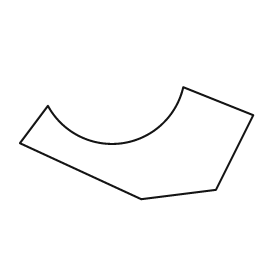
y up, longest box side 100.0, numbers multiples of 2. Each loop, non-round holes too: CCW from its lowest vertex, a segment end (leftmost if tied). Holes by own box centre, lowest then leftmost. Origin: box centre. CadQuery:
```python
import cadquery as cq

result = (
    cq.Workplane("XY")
    .moveTo(2.0, -24.0)
    .lineTo(34.0, -20.0)
    .lineTo(50.0, 12.0)
    .lineTo(20.0, 24.0)
    .threePointArc((-6.0, 0.0), (-38.0, 16.0))
    .lineTo(-50.0, 0.0)
    .close()
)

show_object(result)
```